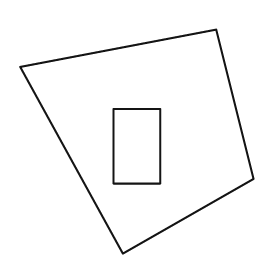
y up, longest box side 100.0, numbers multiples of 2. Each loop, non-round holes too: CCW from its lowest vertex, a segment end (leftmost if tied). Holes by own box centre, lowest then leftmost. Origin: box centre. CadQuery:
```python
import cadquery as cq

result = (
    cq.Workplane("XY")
    .moveTo(-6.0, -48.0)
    .lineTo(50.0, -16.0)
    .lineTo(34.0, 48.0)
    .lineTo(-50.0, 32.0)
    .close()
    .moveTo(-10.0, -18.0)
    .lineTo(10.0, -18.0)
    .lineTo(10.0, 14.0)
    .lineTo(-10.0, 14.0)
    .close()
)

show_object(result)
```